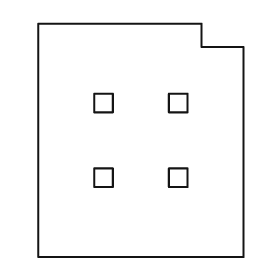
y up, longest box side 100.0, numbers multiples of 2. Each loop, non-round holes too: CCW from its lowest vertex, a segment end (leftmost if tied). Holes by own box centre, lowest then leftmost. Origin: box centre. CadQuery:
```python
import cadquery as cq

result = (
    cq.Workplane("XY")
    .moveTo(-44.0, -50.0)
    .lineTo(44.0, -50.0)
    .lineTo(44.0, 40.0)
    .lineTo(26.0, 40.0)
    .lineTo(26.0, 50.0)
    .lineTo(-44.0, 50.0)
    .close()
    .moveTo(-20.0, -20.0)
    .lineTo(-12.0, -20.0)
    .lineTo(-12.0, -12.0)
    .lineTo(-20.0, -12.0)
    .close()
    .moveTo(12.0, -20.0)
    .lineTo(20.0, -20.0)
    .lineTo(20.0, -12.0)
    .lineTo(12.0, -12.0)
    .close()
    .moveTo(-20.0, 12.0)
    .lineTo(-12.0, 12.0)
    .lineTo(-12.0, 20.0)
    .lineTo(-20.0, 20.0)
    .close()
    .moveTo(12.0, 12.0)
    .lineTo(20.0, 12.0)
    .lineTo(20.0, 20.0)
    .lineTo(12.0, 20.0)
    .close()
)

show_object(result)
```